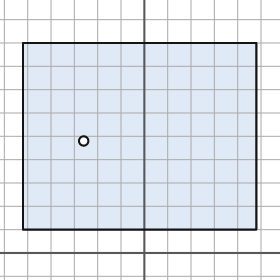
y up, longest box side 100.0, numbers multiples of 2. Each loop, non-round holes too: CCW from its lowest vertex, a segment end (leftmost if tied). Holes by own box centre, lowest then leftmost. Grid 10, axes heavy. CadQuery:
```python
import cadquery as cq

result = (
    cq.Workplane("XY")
    .moveTo(-52.0, 10.0)
    .lineTo(48.0, 10.0)
    .lineTo(48.0, 90.0)
    .lineTo(-52.0, 90.0)
    .close()
    .moveTo(-26.0, 48.0)
    .circle(2.0)
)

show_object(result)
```